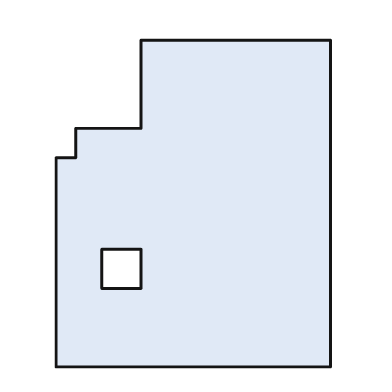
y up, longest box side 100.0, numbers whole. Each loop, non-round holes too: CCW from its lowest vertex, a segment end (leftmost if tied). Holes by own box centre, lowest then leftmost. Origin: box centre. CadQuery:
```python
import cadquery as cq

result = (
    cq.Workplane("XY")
    .moveTo(-42.0, -50.0)
    .lineTo(42.0, -50.0)
    .lineTo(42.0, 50.0)
    .lineTo(-16.0, 50.0)
    .lineTo(-16.0, 23.0)
    .lineTo(-36.0, 23.0)
    .lineTo(-36.0, 14.0)
    .lineTo(-42.0, 14.0)
    .close()
    .moveTo(-28.0, -26.0)
    .lineTo(-16.0, -26.0)
    .lineTo(-16.0, -14.0)
    .lineTo(-28.0, -14.0)
    .close()
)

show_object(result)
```